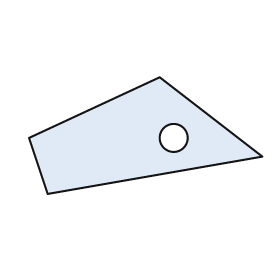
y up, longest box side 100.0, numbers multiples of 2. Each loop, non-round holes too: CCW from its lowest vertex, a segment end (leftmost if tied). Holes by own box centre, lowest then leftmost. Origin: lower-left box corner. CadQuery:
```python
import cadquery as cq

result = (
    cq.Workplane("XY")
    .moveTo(8.0, 0.0)
    .lineTo(100.0, 16.0)
    .lineTo(56.0, 50.0)
    .lineTo(0.0, 24.0)
    .close()
    .moveTo(62.0, 24.0)
    .circle(6.0)
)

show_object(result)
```